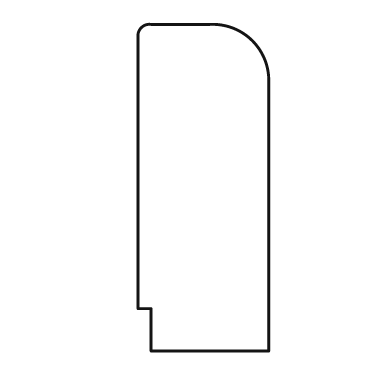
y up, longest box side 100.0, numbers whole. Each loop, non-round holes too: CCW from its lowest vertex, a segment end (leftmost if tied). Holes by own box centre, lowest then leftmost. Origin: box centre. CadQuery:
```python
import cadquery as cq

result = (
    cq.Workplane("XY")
    .moveTo(-16.0, -50.0)
    .lineTo(20.0, -50.0)
    .lineTo(20.0, 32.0)
    .threePointArc((15.0, 45.0), (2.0, 50.0))
    .lineTo(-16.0, 50.0)
    .threePointArc((-19.0, 49.0), (-20.0, 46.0))
    .lineTo(-20.0, -37.0)
    .lineTo(-16.0, -37.0)
    .close()
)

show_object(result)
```